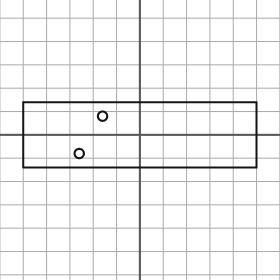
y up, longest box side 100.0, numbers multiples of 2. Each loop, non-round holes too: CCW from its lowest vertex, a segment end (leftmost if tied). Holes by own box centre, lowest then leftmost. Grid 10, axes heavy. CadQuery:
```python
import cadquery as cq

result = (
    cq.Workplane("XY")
    .moveTo(-50.0, -14.0)
    .lineTo(50.0, -14.0)
    .lineTo(50.0, 14.0)
    .lineTo(-50.0, 14.0)
    .close()
    .moveTo(-26.0, -8.0)
    .circle(2.0)
    .moveTo(-16.0, 8.0)
    .circle(2.0)
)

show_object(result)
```